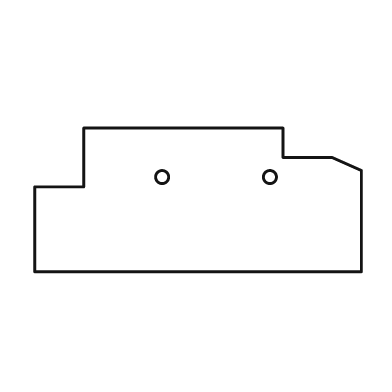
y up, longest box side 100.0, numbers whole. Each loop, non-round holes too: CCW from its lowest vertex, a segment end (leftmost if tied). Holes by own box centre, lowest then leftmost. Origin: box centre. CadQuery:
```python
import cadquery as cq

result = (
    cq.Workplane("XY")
    .moveTo(-50.0, -22.0)
    .lineTo(50.0, -22.0)
    .lineTo(50.0, 9.0)
    .lineTo(41.0, 13.0)
    .lineTo(26.0, 13.0)
    .lineTo(26.0, 22.0)
    .lineTo(-35.0, 22.0)
    .lineTo(-35.0, 4.0)
    .lineTo(-50.0, 4.0)
    .close()
    .moveTo(-11.0, 7.0)
    .circle(2.0)
    .moveTo(22.0, 7.0)
    .circle(2.0)
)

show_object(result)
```